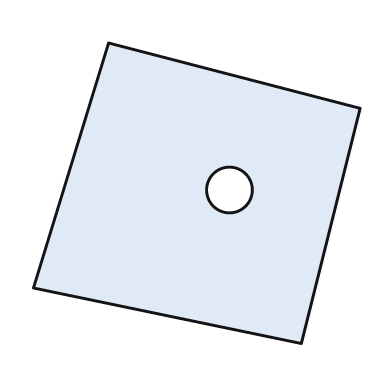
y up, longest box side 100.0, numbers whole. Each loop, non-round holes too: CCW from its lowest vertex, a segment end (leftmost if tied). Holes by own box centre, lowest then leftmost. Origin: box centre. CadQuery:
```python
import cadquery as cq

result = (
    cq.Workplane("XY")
    .moveTo(32.0, -46.0)
    .lineTo(50.0, 26.0)
    .lineTo(-27.0, 46.0)
    .lineTo(-50.0, -29.0)
    .close()
    .moveTo(10.0, 1.0)
    .circle(7.0)
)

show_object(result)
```